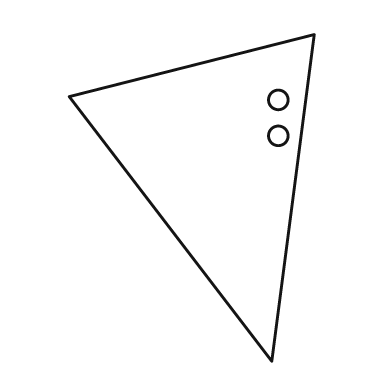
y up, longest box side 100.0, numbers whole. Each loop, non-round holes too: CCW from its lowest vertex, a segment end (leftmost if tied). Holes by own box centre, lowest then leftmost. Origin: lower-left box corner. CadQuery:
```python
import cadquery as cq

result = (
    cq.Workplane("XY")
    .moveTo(62.0, 0.0)
    .lineTo(75.0, 100.0)
    .lineTo(0.0, 81.0)
    .close()
    .moveTo(64.0, 69.0)
    .circle(3.0)
    .moveTo(64.0, 80.0)
    .circle(3.0)
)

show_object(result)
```